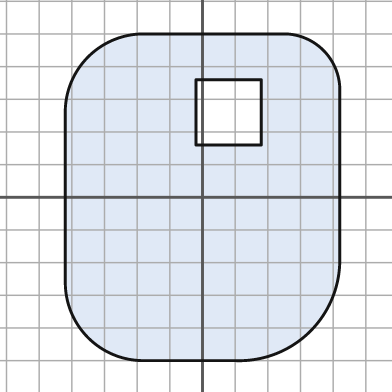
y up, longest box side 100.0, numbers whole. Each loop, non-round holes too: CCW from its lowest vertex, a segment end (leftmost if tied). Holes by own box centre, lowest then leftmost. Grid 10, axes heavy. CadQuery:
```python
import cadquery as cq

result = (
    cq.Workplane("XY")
    .moveTo(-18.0, -50.0)
    .lineTo(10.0, -50.0)
    .threePointArc((33.0, -41.0), (42.0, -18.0))
    .lineTo(42.0, 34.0)
    .threePointArc((37.0, 45.0), (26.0, 50.0))
    .lineTo(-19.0, 50.0)
    .threePointArc((-35.0, 43.0), (-42.0, 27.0))
    .lineTo(-42.0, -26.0)
    .threePointArc((-35.0, -43.0), (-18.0, -50.0))
    .close()
    .moveTo(-2.0, 16.0)
    .lineTo(18.0, 16.0)
    .lineTo(18.0, 36.0)
    .lineTo(-2.0, 36.0)
    .close()
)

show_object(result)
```